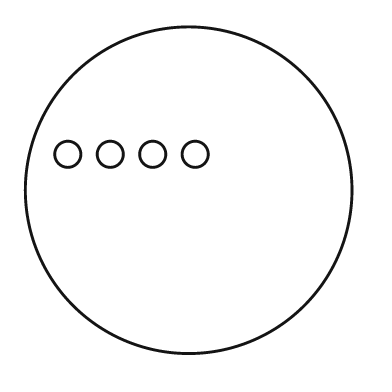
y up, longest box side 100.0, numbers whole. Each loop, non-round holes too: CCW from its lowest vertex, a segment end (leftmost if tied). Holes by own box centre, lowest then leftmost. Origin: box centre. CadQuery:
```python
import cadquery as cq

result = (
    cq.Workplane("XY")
    .moveTo(0.0, 0.0)
    .circle(50.0)
    .moveTo(-37.0, 11.0)
    .circle(4.0)
    .moveTo(-24.0, 11.0)
    .circle(4.0)
    .moveTo(-11.0, 11.0)
    .circle(4.0)
    .moveTo(2.0, 11.0)
    .circle(4.0)
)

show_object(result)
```